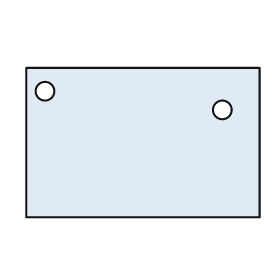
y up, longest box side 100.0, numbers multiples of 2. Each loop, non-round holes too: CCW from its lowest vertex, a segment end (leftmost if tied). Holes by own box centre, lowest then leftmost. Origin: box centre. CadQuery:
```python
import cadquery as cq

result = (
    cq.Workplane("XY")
    .moveTo(-50.0, -32.0)
    .lineTo(50.0, -32.0)
    .lineTo(50.0, 32.0)
    .lineTo(-50.0, 32.0)
    .close()
    .moveTo(34.0, 14.0)
    .circle(4.0)
    .moveTo(-42.0, 22.0)
    .circle(4.0)
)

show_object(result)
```